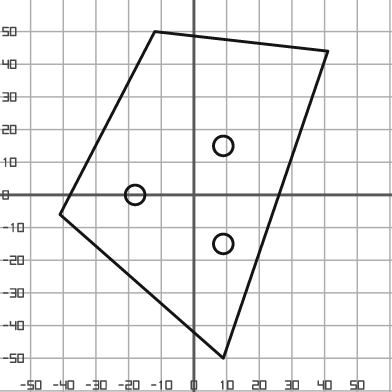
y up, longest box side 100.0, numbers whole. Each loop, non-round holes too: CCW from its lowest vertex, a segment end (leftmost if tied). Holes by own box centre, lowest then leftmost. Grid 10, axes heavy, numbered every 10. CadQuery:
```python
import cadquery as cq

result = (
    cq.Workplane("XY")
    .moveTo(9.0, -50.0)
    .lineTo(41.0, 44.0)
    .lineTo(-12.0, 50.0)
    .lineTo(-41.0, -6.0)
    .close()
    .moveTo(9.0, -15.0)
    .circle(3.0)
    .moveTo(-18.0, 0.0)
    .circle(3.0)
    .moveTo(9.0, 15.0)
    .circle(3.0)
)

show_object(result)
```